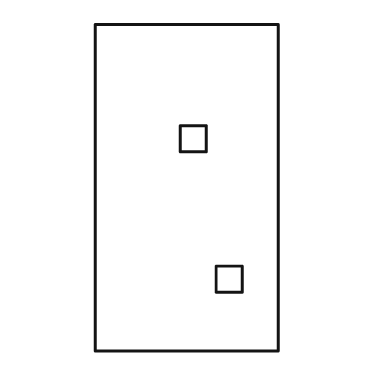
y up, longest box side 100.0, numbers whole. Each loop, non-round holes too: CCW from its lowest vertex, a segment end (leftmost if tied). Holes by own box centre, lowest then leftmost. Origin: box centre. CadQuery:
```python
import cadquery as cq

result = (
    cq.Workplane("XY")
    .moveTo(-28.0, -50.0)
    .lineTo(28.0, -50.0)
    .lineTo(28.0, 50.0)
    .lineTo(-28.0, 50.0)
    .close()
    .moveTo(9.0, -32.0)
    .lineTo(17.0, -32.0)
    .lineTo(17.0, -24.0)
    .lineTo(9.0, -24.0)
    .close()
    .moveTo(-2.0, 11.0)
    .lineTo(6.0, 11.0)
    .lineTo(6.0, 19.0)
    .lineTo(-2.0, 19.0)
    .close()
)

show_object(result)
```